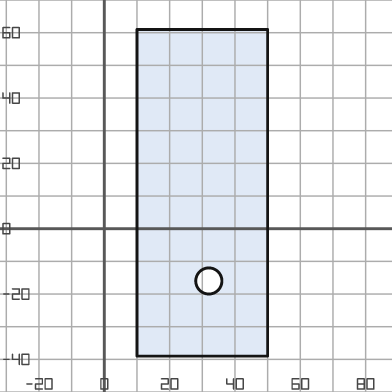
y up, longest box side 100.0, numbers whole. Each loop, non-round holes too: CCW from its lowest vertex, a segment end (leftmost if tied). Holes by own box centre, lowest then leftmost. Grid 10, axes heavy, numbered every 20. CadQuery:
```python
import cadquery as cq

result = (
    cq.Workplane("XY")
    .moveTo(10.0, -39.0)
    .lineTo(50.0, -39.0)
    .lineTo(50.0, 61.0)
    .lineTo(10.0, 61.0)
    .close()
    .moveTo(32.0, -16.0)
    .circle(4.0)
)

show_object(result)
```